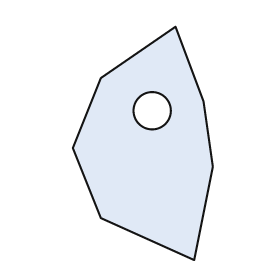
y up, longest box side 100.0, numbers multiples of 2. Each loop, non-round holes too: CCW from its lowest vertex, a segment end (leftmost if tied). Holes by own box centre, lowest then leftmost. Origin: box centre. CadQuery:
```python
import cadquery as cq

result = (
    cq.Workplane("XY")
    .moveTo(22.0, -50.0)
    .lineTo(30.0, -10.0)
    .lineTo(26.0, 18.0)
    .lineTo(14.0, 50.0)
    .lineTo(-18.0, 28.0)
    .lineTo(-30.0, -2.0)
    .lineTo(-18.0, -32.0)
    .close()
    .moveTo(4.0, 14.0)
    .circle(8.0)
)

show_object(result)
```